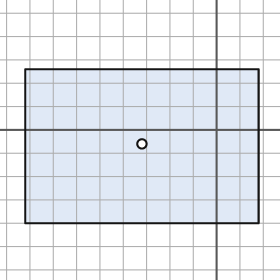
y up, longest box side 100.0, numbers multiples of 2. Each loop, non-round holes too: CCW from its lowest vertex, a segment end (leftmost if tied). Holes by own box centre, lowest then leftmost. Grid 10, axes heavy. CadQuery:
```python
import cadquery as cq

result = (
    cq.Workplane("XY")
    .moveTo(-82.0, -40.0)
    .lineTo(18.0, -40.0)
    .lineTo(18.0, 26.0)
    .lineTo(-82.0, 26.0)
    .close()
    .moveTo(-32.0, -6.0)
    .circle(2.0)
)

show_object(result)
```